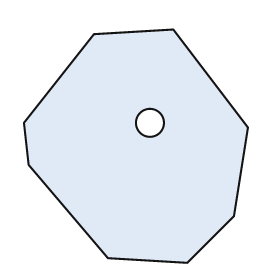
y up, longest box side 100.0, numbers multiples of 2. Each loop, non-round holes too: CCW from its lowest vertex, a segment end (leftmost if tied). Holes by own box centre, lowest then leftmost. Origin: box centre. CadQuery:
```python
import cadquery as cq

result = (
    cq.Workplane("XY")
    .moveTo(22.0, -50.0)
    .lineTo(42.0, -30.0)
    .lineTo(48.0, 8.0)
    .lineTo(16.0, 50.0)
    .lineTo(-18.0, 48.0)
    .lineTo(-48.0, 10.0)
    .lineTo(-46.0, -8.0)
    .lineTo(-12.0, -48.0)
    .close()
    .moveTo(6.0, 10.0)
    .circle(6.0)
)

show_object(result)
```